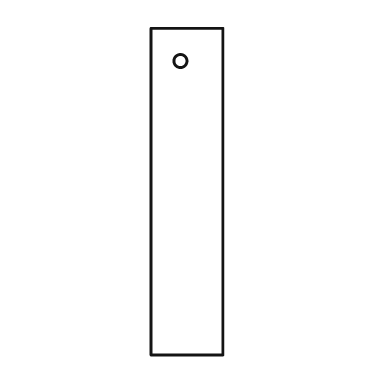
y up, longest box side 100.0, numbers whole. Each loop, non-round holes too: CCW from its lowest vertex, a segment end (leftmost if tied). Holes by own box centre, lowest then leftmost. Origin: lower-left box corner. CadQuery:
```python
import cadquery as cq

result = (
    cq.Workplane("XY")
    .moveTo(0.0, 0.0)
    .lineTo(22.0, 0.0)
    .lineTo(22.0, 100.0)
    .lineTo(0.0, 100.0)
    .close()
    .moveTo(9.0, 90.0)
    .circle(2.0)
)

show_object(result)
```